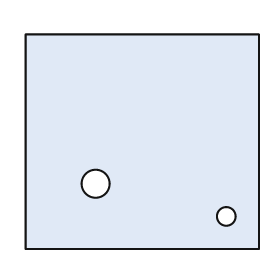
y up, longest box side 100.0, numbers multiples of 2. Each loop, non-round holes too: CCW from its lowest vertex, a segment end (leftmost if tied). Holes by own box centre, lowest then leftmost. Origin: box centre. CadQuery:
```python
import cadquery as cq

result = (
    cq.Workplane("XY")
    .moveTo(-50.0, -46.0)
    .lineTo(50.0, -46.0)
    .lineTo(50.0, 46.0)
    .lineTo(-50.0, 46.0)
    .close()
    .moveTo(36.0, -32.0)
    .circle(4.0)
    .moveTo(-20.0, -18.0)
    .circle(6.0)
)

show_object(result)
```